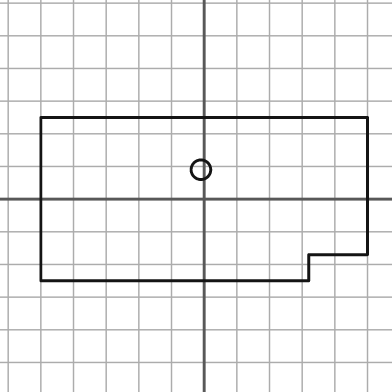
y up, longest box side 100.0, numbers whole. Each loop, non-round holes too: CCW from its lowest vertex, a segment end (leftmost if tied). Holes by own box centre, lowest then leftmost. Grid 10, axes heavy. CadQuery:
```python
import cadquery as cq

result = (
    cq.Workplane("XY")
    .moveTo(-50.0, -25.0)
    .lineTo(32.0, -25.0)
    .lineTo(32.0, -17.0)
    .lineTo(50.0, -17.0)
    .lineTo(50.0, 25.0)
    .lineTo(-50.0, 25.0)
    .close()
    .moveTo(-1.0, 9.0)
    .circle(3.0)
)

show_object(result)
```